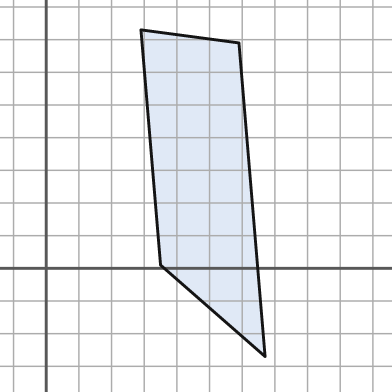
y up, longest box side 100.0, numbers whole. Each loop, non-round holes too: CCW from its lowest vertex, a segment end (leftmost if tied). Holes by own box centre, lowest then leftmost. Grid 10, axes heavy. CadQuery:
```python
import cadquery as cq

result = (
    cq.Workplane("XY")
    .moveTo(67.0, -27.0)
    .lineTo(59.0, 69.0)
    .lineTo(29.0, 73.0)
    .lineTo(35.0, 1.0)
    .close()
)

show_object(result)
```